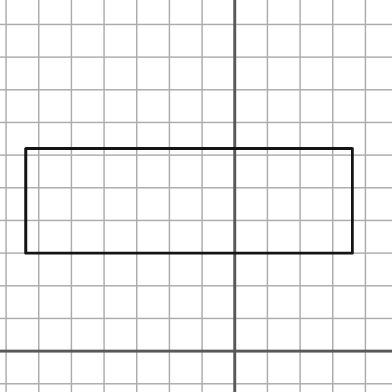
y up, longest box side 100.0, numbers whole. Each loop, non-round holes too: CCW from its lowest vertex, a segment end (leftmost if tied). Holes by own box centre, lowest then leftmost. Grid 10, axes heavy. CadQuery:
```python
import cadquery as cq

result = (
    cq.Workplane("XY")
    .moveTo(-64.0, 30.0)
    .lineTo(36.0, 30.0)
    .lineTo(36.0, 62.0)
    .lineTo(-64.0, 62.0)
    .close()
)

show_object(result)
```